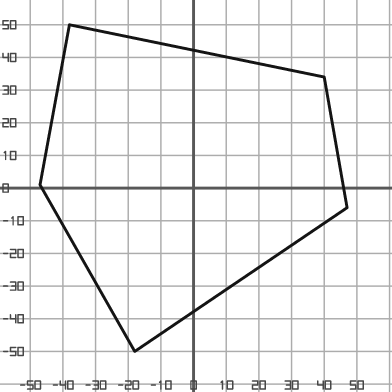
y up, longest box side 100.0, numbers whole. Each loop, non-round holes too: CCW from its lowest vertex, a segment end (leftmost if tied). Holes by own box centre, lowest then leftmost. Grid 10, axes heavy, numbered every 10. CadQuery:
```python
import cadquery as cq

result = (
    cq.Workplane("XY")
    .moveTo(-18.0, -50.0)
    .lineTo(47.0, -6.0)
    .lineTo(40.0, 34.0)
    .lineTo(-38.0, 50.0)
    .lineTo(-47.0, 1.0)
    .close()
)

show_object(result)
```